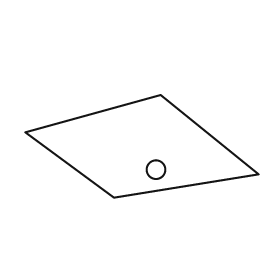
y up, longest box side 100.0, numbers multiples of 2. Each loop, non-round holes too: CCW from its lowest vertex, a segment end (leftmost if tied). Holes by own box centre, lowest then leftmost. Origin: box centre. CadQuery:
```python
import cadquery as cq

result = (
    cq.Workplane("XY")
    .moveTo(-12.0, -22.0)
    .lineTo(50.0, -12.0)
    .lineTo(8.0, 22.0)
    .lineTo(-50.0, 6.0)
    .close()
    .moveTo(6.0, -10.0)
    .circle(4.0)
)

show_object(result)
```